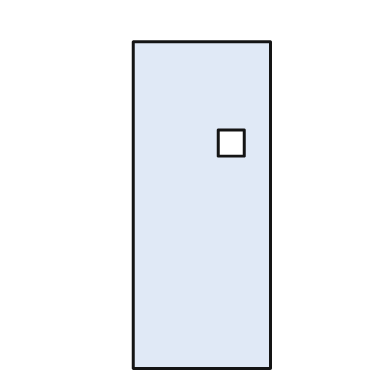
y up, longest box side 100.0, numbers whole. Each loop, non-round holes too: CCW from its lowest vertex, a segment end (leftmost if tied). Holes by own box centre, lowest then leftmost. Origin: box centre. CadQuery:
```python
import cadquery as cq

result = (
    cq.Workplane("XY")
    .moveTo(-21.0, -50.0)
    .lineTo(21.0, -50.0)
    .lineTo(21.0, 50.0)
    .lineTo(-21.0, 50.0)
    .close()
    .moveTo(5.0, 15.0)
    .lineTo(13.0, 15.0)
    .lineTo(13.0, 23.0)
    .lineTo(5.0, 23.0)
    .close()
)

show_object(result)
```